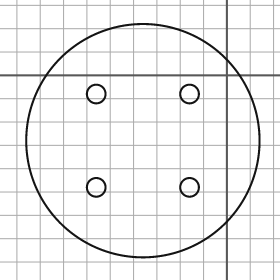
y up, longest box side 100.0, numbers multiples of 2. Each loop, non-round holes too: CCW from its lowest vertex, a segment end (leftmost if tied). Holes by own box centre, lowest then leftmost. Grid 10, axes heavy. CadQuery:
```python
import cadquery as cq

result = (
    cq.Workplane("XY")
    .moveTo(-36.0, -28.0)
    .circle(50.0)
    .moveTo(-56.0, -48.0)
    .circle(4.0)
    .moveTo(-16.0, -48.0)
    .circle(4.0)
    .moveTo(-56.0, -8.0)
    .circle(4.0)
    .moveTo(-16.0, -8.0)
    .circle(4.0)
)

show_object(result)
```